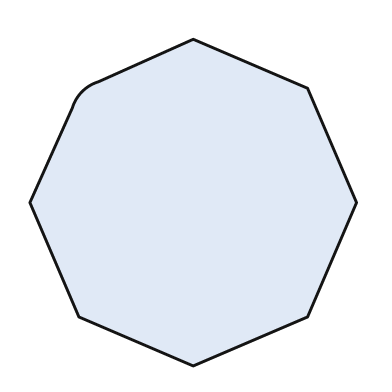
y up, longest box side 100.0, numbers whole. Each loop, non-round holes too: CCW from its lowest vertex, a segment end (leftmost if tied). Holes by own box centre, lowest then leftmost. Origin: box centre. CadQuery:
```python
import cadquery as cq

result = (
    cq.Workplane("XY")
    .moveTo(0.0, -50.0)
    .lineTo(35.0, -35.0)
    .lineTo(50.0, 0.0)
    .lineTo(35.0, 35.0)
    .lineTo(0.0, 50.0)
    .lineTo(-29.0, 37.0)
    .threePointArc((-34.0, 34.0), (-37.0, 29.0))
    .lineTo(-50.0, 0.0)
    .lineTo(-35.0, -35.0)
    .close()
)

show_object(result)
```